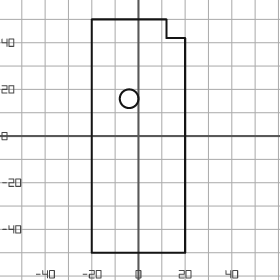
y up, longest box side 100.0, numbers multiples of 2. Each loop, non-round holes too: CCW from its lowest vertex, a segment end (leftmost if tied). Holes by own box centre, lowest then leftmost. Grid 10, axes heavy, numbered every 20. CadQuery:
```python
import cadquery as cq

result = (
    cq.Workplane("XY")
    .moveTo(-20.0, -50.0)
    .lineTo(20.0, -50.0)
    .lineTo(20.0, 42.0)
    .lineTo(12.0, 42.0)
    .lineTo(12.0, 50.0)
    .lineTo(-20.0, 50.0)
    .close()
    .moveTo(-4.0, 16.0)
    .circle(4.0)
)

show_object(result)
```